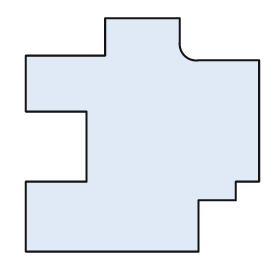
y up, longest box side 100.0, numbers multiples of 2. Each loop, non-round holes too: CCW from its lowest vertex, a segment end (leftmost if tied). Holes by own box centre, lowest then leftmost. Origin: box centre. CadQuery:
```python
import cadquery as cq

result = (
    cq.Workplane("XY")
    .moveTo(-50.0, -50.0)
    .lineTo(24.0, -50.0)
    .lineTo(24.0, -28.0)
    .lineTo(40.0, -28.0)
    .lineTo(40.0, -20.0)
    .lineTo(50.0, -20.0)
    .lineTo(50.0, 32.0)
    .lineTo(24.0, 32.0)
    .threePointArc((18.0, 34.0), (16.0, 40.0))
    .lineTo(16.0, 50.0)
    .lineTo(-16.0, 50.0)
    .lineTo(-16.0, 34.0)
    .lineTo(-50.0, 34.0)
    .lineTo(-50.0, 10.0)
    .lineTo(-24.0, 10.0)
    .lineTo(-24.0, -20.0)
    .lineTo(-50.0, -20.0)
    .close()
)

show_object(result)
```